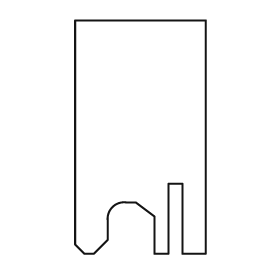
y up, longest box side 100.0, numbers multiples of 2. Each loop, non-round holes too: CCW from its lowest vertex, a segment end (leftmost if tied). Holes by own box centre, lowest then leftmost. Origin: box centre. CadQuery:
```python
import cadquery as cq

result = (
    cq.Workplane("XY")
    .moveTo(-24.0, -50.0)
    .lineTo(-20.0, -50.0)
    .lineTo(-14.0, -44.0)
    .lineTo(-14.0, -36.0)
    .threePointArc((-12.0, -30.0), (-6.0, -28.0))
    .lineTo(-2.0, -28.0)
    .lineTo(6.0, -34.0)
    .lineTo(6.0, -50.0)
    .lineTo(12.0, -50.0)
    .lineTo(12.0, -20.0)
    .lineTo(18.0, -20.0)
    .lineTo(18.0, -50.0)
    .lineTo(28.0, -50.0)
    .lineTo(28.0, 50.0)
    .lineTo(-28.0, 50.0)
    .lineTo(-28.0, -46.0)
    .close()
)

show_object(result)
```